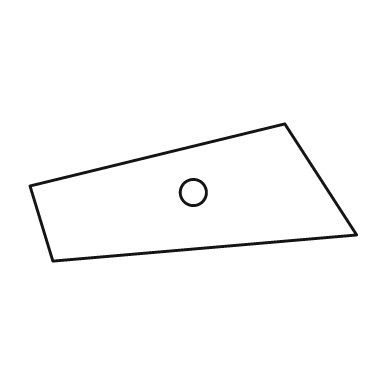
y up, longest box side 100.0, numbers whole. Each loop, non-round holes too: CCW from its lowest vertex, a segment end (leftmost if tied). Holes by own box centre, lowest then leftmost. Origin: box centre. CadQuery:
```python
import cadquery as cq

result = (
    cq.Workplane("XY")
    .moveTo(-43.0, -21.0)
    .lineTo(50.0, -13.0)
    .lineTo(28.0, 21.0)
    .lineTo(-50.0, 2.0)
    .close()
    .moveTo(0.0, 0.0)
    .circle(4.0)
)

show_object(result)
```